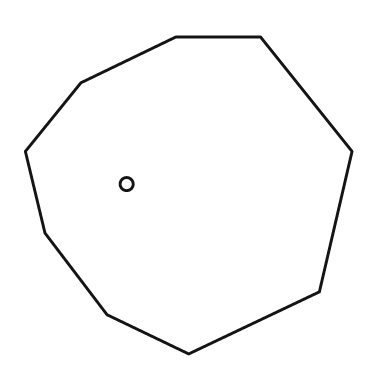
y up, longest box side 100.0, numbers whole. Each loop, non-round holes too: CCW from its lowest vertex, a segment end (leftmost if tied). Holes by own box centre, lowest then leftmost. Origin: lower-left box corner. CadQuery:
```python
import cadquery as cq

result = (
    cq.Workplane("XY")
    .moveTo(50.0, 0.0)
    .lineTo(90.0, 19.0)
    .lineTo(100.0, 62.0)
    .lineTo(72.0, 97.0)
    .lineTo(46.0, 97.0)
    .lineTo(17.0, 83.0)
    .lineTo(0.0, 62.0)
    .lineTo(6.0, 37.0)
    .lineTo(25.0, 12.0)
    .close()
    .moveTo(31.0, 52.0)
    .circle(2.0)
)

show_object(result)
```